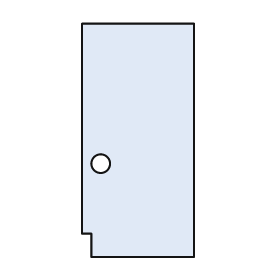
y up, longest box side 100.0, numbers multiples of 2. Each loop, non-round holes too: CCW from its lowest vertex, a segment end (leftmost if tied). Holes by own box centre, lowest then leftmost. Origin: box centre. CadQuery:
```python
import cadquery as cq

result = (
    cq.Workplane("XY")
    .moveTo(-20.0, -50.0)
    .lineTo(24.0, -50.0)
    .lineTo(24.0, 50.0)
    .lineTo(-24.0, 50.0)
    .lineTo(-24.0, -40.0)
    .lineTo(-20.0, -40.0)
    .close()
    .moveTo(-16.0, -10.0)
    .circle(4.0)
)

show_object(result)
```